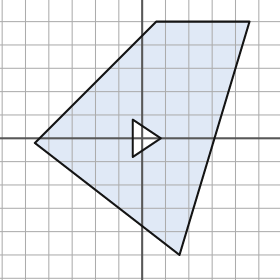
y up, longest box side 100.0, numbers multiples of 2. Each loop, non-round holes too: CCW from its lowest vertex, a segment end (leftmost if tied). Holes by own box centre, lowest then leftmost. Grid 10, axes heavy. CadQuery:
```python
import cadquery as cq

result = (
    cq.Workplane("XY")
    .moveTo(16.0, -50.0)
    .lineTo(46.0, 50.0)
    .lineTo(6.0, 50.0)
    .lineTo(-46.0, -2.0)
    .close()
    .moveTo(-4.0, -8.0)
    .lineTo(8.0, 0.0)
    .lineTo(-4.0, 8.0)
    .close()
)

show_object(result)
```